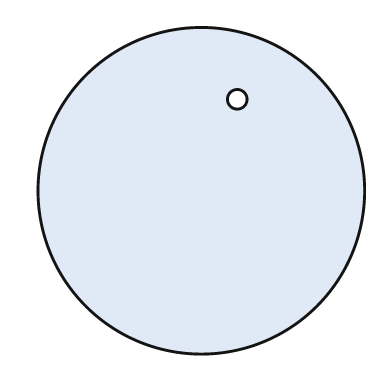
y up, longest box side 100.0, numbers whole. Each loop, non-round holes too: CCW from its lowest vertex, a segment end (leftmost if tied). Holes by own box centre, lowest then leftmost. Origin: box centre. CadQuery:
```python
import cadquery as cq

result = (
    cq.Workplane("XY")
    .moveTo(0.0, 0.0)
    .circle(50.0)
    .moveTo(11.0, 28.0)
    .circle(3.0)
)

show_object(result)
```